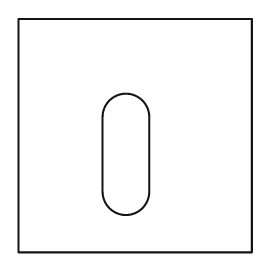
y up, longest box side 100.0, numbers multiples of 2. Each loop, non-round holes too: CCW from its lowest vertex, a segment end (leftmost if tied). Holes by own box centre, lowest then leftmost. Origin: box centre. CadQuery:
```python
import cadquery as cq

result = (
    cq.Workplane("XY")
    .moveTo(-50.0, -50.0)
    .lineTo(50.0, -50.0)
    .lineTo(50.0, 50.0)
    .lineTo(-50.0, 50.0)
    .close()
    .moveTo(-14.0, -24.0)
    .threePointArc((-4.0, -34.0), (6.0, -24.0))
    .lineTo(6.0, 8.0)
    .threePointArc((-4.0, 18.0), (-14.0, 8.0))
    .close()
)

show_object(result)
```